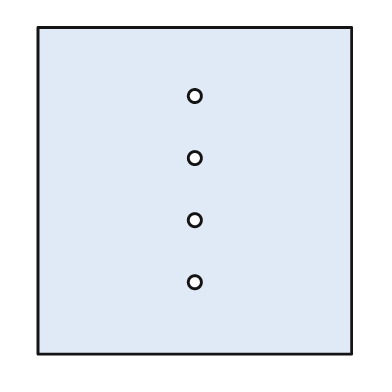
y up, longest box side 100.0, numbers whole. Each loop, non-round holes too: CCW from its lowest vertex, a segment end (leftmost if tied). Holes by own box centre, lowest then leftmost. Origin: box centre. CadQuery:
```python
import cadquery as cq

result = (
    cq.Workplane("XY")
    .moveTo(-48.0, -50.0)
    .lineTo(48.0, -50.0)
    .lineTo(48.0, 50.0)
    .lineTo(-48.0, 50.0)
    .close()
    .moveTo(0.0, -28.0)
    .circle(2.0)
    .moveTo(0.0, -9.0)
    .circle(2.0)
    .moveTo(0.0, 10.0)
    .circle(2.0)
    .moveTo(0.0, 29.0)
    .circle(2.0)
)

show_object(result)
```